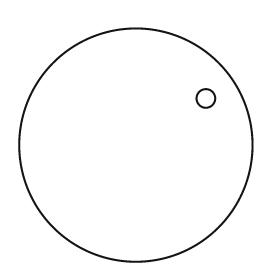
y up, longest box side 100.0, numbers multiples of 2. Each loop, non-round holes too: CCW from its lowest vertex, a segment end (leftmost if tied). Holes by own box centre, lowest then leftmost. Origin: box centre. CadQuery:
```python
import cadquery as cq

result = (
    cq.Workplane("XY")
    .moveTo(0.0, 0.0)
    .circle(50.0)
    .moveTo(30.0, 20.0)
    .circle(4.0)
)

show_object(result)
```